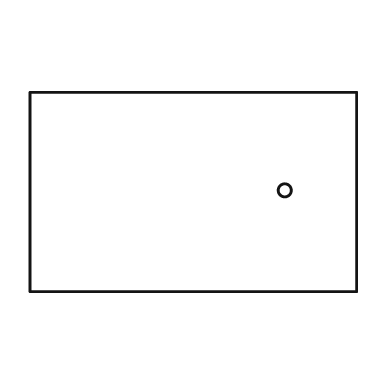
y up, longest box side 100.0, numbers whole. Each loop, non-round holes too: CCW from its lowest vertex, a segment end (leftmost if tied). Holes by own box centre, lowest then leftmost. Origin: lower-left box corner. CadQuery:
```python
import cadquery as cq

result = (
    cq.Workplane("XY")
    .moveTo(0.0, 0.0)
    .lineTo(100.0, 0.0)
    .lineTo(100.0, 61.0)
    .lineTo(0.0, 61.0)
    .close()
    .moveTo(78.0, 31.0)
    .circle(2.0)
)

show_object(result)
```